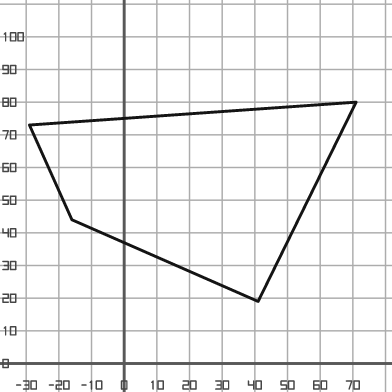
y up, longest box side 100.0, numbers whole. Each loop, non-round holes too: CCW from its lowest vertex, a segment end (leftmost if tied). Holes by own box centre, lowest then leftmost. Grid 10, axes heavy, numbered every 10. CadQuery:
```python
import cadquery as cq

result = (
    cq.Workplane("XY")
    .moveTo(41.0, 19.0)
    .lineTo(71.0, 80.0)
    .lineTo(-29.0, 73.0)
    .lineTo(-16.0, 44.0)
    .close()
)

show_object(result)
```